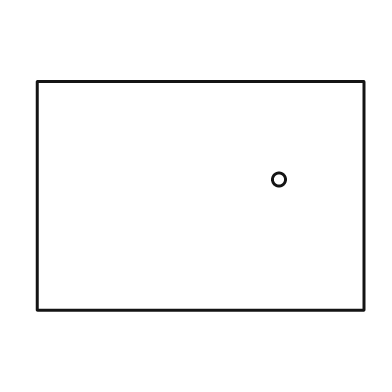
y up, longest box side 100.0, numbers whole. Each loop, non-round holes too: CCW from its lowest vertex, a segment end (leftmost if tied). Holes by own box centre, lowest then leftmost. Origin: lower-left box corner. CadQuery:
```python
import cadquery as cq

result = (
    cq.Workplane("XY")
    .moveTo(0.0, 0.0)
    .lineTo(100.0, 0.0)
    .lineTo(100.0, 70.0)
    .lineTo(0.0, 70.0)
    .close()
    .moveTo(74.0, 40.0)
    .circle(2.0)
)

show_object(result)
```